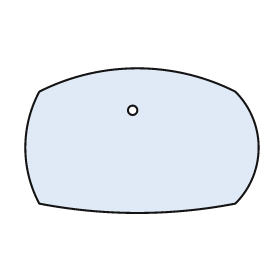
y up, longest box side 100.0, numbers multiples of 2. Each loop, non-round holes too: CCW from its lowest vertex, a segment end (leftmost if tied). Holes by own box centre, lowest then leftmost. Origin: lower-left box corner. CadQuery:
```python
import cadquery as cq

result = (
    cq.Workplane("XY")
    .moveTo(6.0, 4.0)
    .threePointArc((48.0, 0.0), (90.0, 4.0))
    .threePointArc((100.0, 28.0), (90.0, 52.0))
    .threePointArc((48.0, 62.0), (6.0, 52.0))
    .threePointArc((0.0, 28.0), (6.0, 4.0))
    .close()
    .moveTo(46.0, 44.0)
    .circle(2.0)
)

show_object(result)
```